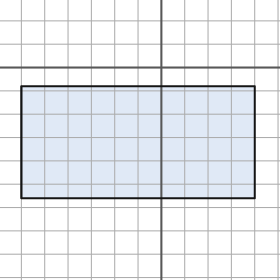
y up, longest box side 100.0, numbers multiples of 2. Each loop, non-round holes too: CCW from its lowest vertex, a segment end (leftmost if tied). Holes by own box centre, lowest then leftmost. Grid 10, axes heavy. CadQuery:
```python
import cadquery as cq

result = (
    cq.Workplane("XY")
    .moveTo(-60.0, -56.0)
    .lineTo(40.0, -56.0)
    .lineTo(40.0, -8.0)
    .lineTo(-60.0, -8.0)
    .close()
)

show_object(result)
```